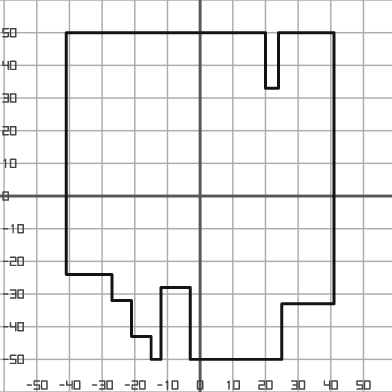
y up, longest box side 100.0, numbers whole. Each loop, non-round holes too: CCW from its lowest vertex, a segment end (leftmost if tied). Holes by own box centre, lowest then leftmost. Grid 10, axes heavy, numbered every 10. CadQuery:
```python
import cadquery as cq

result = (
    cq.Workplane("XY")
    .moveTo(-15.0, -50.0)
    .lineTo(-12.0, -50.0)
    .lineTo(-12.0, -28.0)
    .lineTo(-3.0, -28.0)
    .lineTo(-3.0, -50.0)
    .lineTo(25.0, -50.0)
    .lineTo(25.0, -33.0)
    .lineTo(41.0, -33.0)
    .lineTo(41.0, 50.0)
    .lineTo(24.0, 50.0)
    .lineTo(24.0, 33.0)
    .lineTo(20.0, 33.0)
    .lineTo(20.0, 50.0)
    .lineTo(-41.0, 50.0)
    .lineTo(-41.0, -24.0)
    .lineTo(-27.0, -24.0)
    .lineTo(-27.0, -32.0)
    .lineTo(-21.0, -32.0)
    .lineTo(-21.0, -43.0)
    .lineTo(-15.0, -43.0)
    .close()
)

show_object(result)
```